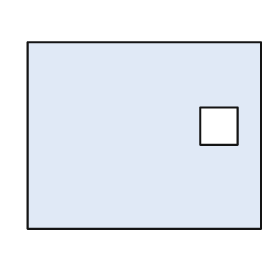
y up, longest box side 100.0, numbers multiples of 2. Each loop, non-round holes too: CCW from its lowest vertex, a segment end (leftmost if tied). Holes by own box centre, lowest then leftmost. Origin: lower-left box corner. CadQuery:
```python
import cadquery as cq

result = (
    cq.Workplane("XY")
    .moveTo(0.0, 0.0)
    .lineTo(100.0, 0.0)
    .lineTo(100.0, 80.0)
    .lineTo(0.0, 80.0)
    .close()
    .moveTo(74.0, 36.0)
    .lineTo(90.0, 36.0)
    .lineTo(90.0, 52.0)
    .lineTo(74.0, 52.0)
    .close()
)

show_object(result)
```